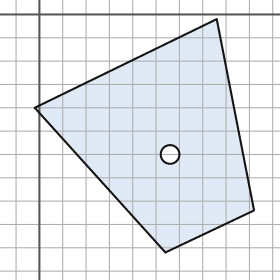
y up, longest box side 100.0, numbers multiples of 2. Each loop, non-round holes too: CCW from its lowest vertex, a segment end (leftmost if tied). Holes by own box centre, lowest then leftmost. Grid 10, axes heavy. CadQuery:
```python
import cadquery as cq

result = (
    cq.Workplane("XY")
    .moveTo(54.0, -102.0)
    .lineTo(92.0, -84.0)
    .lineTo(76.0, -2.0)
    .lineTo(-2.0, -40.0)
    .close()
    .moveTo(56.0, -60.0)
    .circle(4.0)
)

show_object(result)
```